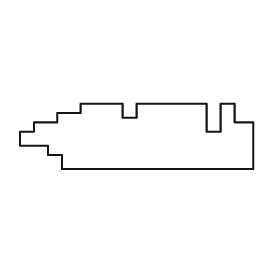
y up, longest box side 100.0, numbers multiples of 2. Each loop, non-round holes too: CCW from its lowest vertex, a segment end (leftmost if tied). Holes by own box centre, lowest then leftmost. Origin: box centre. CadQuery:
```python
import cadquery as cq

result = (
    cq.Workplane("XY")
    .moveTo(-32.0, -14.0)
    .lineTo(50.0, -14.0)
    .lineTo(50.0, 6.0)
    .lineTo(42.0, 6.0)
    .lineTo(42.0, 14.0)
    .lineTo(36.0, 14.0)
    .lineTo(36.0, 2.0)
    .lineTo(30.0, 2.0)
    .lineTo(30.0, 14.0)
    .lineTo(0.0, 14.0)
    .lineTo(0.0, 8.0)
    .lineTo(-6.0, 8.0)
    .lineTo(-6.0, 14.0)
    .lineTo(-24.0, 14.0)
    .lineTo(-24.0, 10.0)
    .lineTo(-34.0, 10.0)
    .lineTo(-34.0, 6.0)
    .lineTo(-44.0, 6.0)
    .lineTo(-44.0, 2.0)
    .lineTo(-50.0, 2.0)
    .lineTo(-50.0, -4.0)
    .lineTo(-38.0, -4.0)
    .lineTo(-38.0, -8.0)
    .lineTo(-32.0, -8.0)
    .close()
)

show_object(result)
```